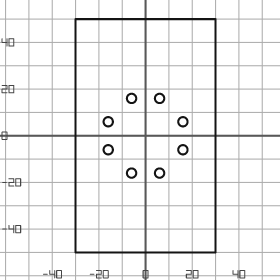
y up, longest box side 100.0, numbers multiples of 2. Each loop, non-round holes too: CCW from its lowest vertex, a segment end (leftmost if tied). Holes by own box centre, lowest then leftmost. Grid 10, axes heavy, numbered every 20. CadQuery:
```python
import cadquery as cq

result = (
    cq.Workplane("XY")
    .moveTo(-30.0, -50.0)
    .lineTo(30.0, -50.0)
    .lineTo(30.0, 50.0)
    .lineTo(-30.0, 50.0)
    .close()
    .moveTo(-6.0, -16.0)
    .circle(2.0)
    .moveTo(6.0, -16.0)
    .circle(2.0)
    .moveTo(-16.0, -6.0)
    .circle(2.0)
    .moveTo(16.0, -6.0)
    .circle(2.0)
    .moveTo(-16.0, 6.0)
    .circle(2.0)
    .moveTo(16.0, 6.0)
    .circle(2.0)
    .moveTo(-6.0, 16.0)
    .circle(2.0)
    .moveTo(6.0, 16.0)
    .circle(2.0)
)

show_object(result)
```